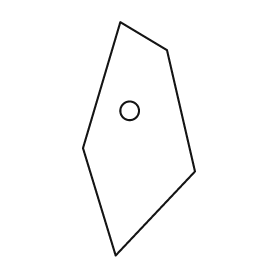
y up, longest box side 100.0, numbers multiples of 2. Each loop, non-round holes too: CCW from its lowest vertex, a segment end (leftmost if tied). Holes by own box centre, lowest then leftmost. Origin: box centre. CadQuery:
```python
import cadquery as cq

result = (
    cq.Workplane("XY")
    .moveTo(-10.0, -50.0)
    .lineTo(24.0, -14.0)
    .lineTo(12.0, 38.0)
    .lineTo(-8.0, 50.0)
    .lineTo(-24.0, -4.0)
    .close()
    .moveTo(-4.0, 12.0)
    .circle(4.0)
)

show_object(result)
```